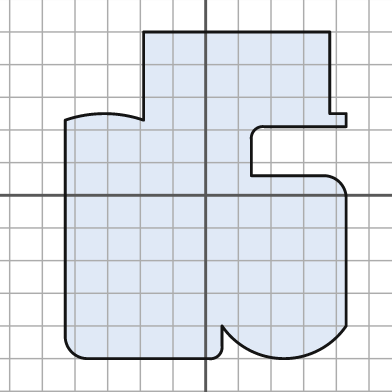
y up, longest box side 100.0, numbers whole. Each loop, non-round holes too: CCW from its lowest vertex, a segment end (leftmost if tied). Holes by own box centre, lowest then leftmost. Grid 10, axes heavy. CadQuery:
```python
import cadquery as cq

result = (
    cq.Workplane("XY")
    .moveTo(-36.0, -50.0)
    .lineTo(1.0, -50.0)
    .threePointArc((4.0, -49.0), (5.0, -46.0))
    .lineTo(5.0, -40.0)
    .threePointArc((24.0, -50.0), (43.0, -40.0))
    .lineTo(43.0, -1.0)
    .threePointArc((41.0, 4.0), (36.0, 6.0))
    .lineTo(14.0, 6.0)
    .lineTo(14.0, 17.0)
    .threePointArc((15.0, 20.0), (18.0, 21.0))
    .lineTo(43.0, 21.0)
    .lineTo(43.0, 25.0)
    .lineTo(38.0, 25.0)
    .lineTo(38.0, 50.0)
    .lineTo(-19.0, 50.0)
    .lineTo(-19.0, 23.0)
    .threePointArc((-31.0, 25.0), (-43.0, 23.0))
    .lineTo(-43.0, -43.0)
    .threePointArc((-41.0, -48.0), (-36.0, -50.0))
    .close()
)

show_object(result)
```